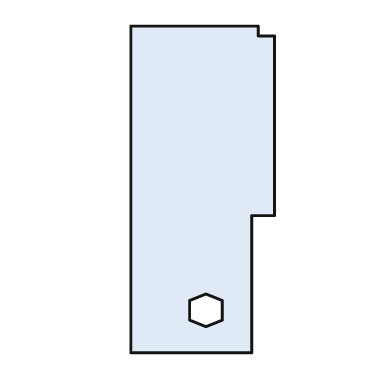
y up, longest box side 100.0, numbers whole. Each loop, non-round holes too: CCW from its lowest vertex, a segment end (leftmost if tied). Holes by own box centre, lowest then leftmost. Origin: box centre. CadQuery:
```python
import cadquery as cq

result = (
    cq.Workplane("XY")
    .moveTo(-22.0, -50.0)
    .lineTo(15.0, -50.0)
    .lineTo(15.0, -8.0)
    .lineTo(22.0, -8.0)
    .lineTo(22.0, 47.0)
    .lineTo(17.0, 47.0)
    .lineTo(17.0, 50.0)
    .lineTo(-22.0, 50.0)
    .close()
    .moveTo(1.0, -42.0)
    .lineTo(6.0, -40.0)
    .lineTo(6.0, -34.0)
    .lineTo(1.0, -32.0)
    .lineTo(-4.0, -34.0)
    .lineTo(-4.0, -40.0)
    .close()
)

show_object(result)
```